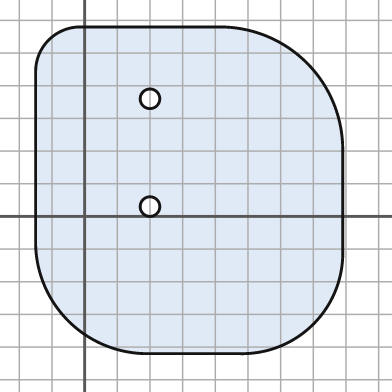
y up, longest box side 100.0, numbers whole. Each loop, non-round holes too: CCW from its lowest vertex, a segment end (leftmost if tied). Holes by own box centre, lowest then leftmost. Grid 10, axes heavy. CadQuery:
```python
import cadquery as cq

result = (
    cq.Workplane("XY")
    .moveTo(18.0, -42.0)
    .lineTo(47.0, -42.0)
    .threePointArc((70.0, -33.0), (79.0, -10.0))
    .lineTo(79.0, 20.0)
    .threePointArc((68.0, 47.0), (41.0, 58.0))
    .lineTo(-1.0, 58.0)
    .threePointArc((-11.0, 54.0), (-15.0, 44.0))
    .lineTo(-15.0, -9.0)
    .threePointArc((-5.0, -32.0), (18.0, -42.0))
    .close()
    .moveTo(20.0, 3.0)
    .circle(3.0)
    .moveTo(20.0, 36.0)
    .circle(3.0)
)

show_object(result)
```